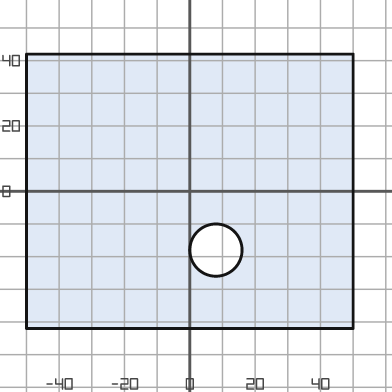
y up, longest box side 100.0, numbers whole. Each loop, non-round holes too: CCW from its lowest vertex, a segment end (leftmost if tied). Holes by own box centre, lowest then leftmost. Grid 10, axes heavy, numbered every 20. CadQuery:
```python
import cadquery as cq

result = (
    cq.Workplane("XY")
    .moveTo(-50.0, -42.0)
    .lineTo(50.0, -42.0)
    .lineTo(50.0, 42.0)
    .lineTo(-50.0, 42.0)
    .close()
    .moveTo(8.0, -18.0)
    .circle(8.0)
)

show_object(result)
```